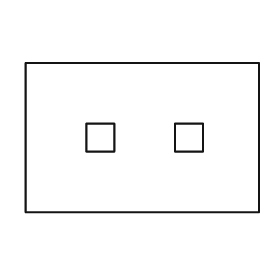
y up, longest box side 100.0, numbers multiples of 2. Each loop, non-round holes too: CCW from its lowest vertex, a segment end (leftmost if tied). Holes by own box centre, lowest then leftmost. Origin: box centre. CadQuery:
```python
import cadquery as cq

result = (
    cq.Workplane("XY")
    .moveTo(-50.0, -32.0)
    .lineTo(50.0, -32.0)
    .lineTo(50.0, 32.0)
    .lineTo(-50.0, 32.0)
    .close()
    .moveTo(-24.0, -6.0)
    .lineTo(-12.0, -6.0)
    .lineTo(-12.0, 6.0)
    .lineTo(-24.0, 6.0)
    .close()
    .moveTo(14.0, -6.0)
    .lineTo(26.0, -6.0)
    .lineTo(26.0, 6.0)
    .lineTo(14.0, 6.0)
    .close()
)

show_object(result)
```